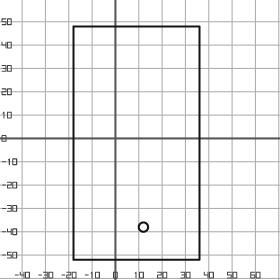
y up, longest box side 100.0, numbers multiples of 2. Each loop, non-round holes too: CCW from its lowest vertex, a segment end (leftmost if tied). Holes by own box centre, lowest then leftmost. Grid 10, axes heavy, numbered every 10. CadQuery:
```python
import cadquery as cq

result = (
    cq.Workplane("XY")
    .moveTo(-18.0, -52.0)
    .lineTo(36.0, -52.0)
    .lineTo(36.0, 48.0)
    .lineTo(-18.0, 48.0)
    .close()
    .moveTo(12.0, -38.0)
    .circle(2.0)
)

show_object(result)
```